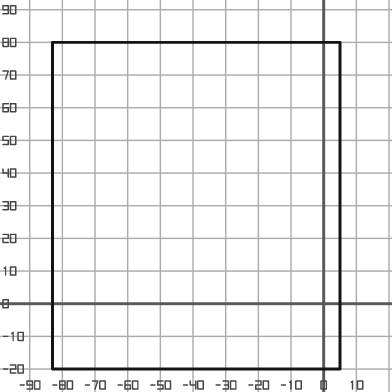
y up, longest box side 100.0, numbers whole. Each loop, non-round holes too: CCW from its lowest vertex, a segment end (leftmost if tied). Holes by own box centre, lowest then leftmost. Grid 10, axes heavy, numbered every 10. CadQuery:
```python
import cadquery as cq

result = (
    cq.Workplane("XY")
    .moveTo(-83.0, -20.0)
    .lineTo(5.0, -20.0)
    .lineTo(5.0, 80.0)
    .lineTo(-83.0, 80.0)
    .close()
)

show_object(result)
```